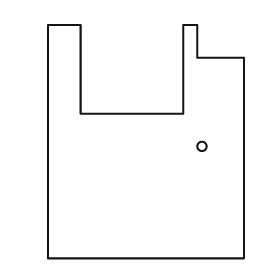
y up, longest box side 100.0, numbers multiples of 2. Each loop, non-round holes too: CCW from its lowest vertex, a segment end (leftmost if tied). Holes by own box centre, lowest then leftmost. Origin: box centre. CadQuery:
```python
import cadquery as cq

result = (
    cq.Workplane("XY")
    .moveTo(-42.0, -50.0)
    .lineTo(42.0, -50.0)
    .lineTo(42.0, 36.0)
    .lineTo(22.0, 36.0)
    .lineTo(22.0, 50.0)
    .lineTo(16.0, 50.0)
    .lineTo(16.0, 12.0)
    .lineTo(-28.0, 12.0)
    .lineTo(-28.0, 50.0)
    .lineTo(-42.0, 50.0)
    .close()
    .moveTo(24.0, -2.0)
    .circle(2.0)
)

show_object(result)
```